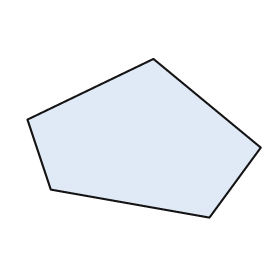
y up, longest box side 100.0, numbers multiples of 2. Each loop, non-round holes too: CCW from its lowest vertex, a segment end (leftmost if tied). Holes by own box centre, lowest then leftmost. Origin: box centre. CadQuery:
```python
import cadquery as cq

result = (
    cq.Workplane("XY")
    .moveTo(28.0, -34.0)
    .lineTo(50.0, -4.0)
    .lineTo(4.0, 34.0)
    .lineTo(-50.0, 8.0)
    .lineTo(-40.0, -22.0)
    .close()
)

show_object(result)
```